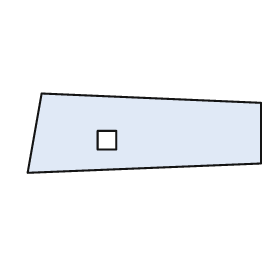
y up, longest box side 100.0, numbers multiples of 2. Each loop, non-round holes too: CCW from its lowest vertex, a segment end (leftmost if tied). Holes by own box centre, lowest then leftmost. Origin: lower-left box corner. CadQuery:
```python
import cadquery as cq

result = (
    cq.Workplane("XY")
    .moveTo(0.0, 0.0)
    .lineTo(100.0, 4.0)
    .lineTo(100.0, 30.0)
    .lineTo(6.0, 34.0)
    .close()
    .moveTo(30.0, 10.0)
    .lineTo(38.0, 10.0)
    .lineTo(38.0, 18.0)
    .lineTo(30.0, 18.0)
    .close()
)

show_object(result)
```